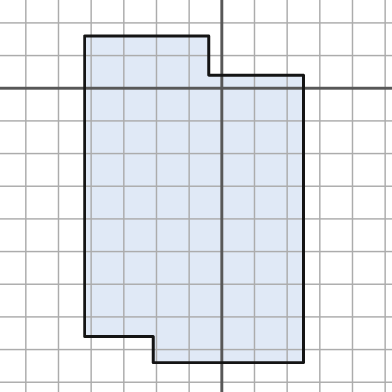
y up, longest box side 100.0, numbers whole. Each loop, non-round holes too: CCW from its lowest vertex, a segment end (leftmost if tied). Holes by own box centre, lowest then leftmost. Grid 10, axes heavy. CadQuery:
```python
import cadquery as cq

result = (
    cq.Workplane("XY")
    .moveTo(-21.0, -84.0)
    .lineTo(25.0, -84.0)
    .lineTo(25.0, 4.0)
    .lineTo(-4.0, 4.0)
    .lineTo(-4.0, 16.0)
    .lineTo(-42.0, 16.0)
    .lineTo(-42.0, -76.0)
    .lineTo(-21.0, -76.0)
    .close()
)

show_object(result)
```